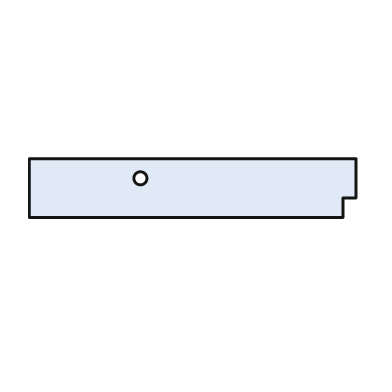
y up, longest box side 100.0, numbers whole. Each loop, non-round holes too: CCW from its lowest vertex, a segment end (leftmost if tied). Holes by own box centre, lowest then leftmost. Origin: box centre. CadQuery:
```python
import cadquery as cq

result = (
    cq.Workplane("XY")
    .moveTo(-50.0, -9.0)
    .lineTo(46.0, -9.0)
    .lineTo(46.0, -3.0)
    .lineTo(50.0, -3.0)
    .lineTo(50.0, 9.0)
    .lineTo(-50.0, 9.0)
    .close()
    .moveTo(-16.0, 3.0)
    .circle(2.0)
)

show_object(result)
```